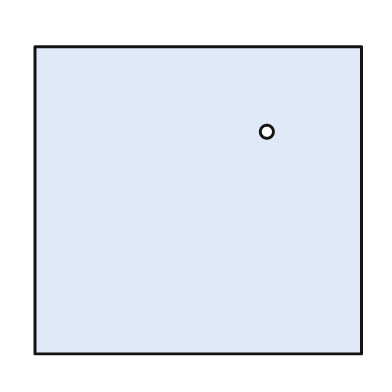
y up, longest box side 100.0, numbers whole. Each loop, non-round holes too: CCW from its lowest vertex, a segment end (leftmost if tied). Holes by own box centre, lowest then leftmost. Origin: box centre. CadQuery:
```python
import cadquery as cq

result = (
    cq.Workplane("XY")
    .moveTo(-50.0, -47.0)
    .lineTo(50.0, -47.0)
    .lineTo(50.0, 47.0)
    .lineTo(-50.0, 47.0)
    .close()
    .moveTo(21.0, 21.0)
    .circle(2.0)
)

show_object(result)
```